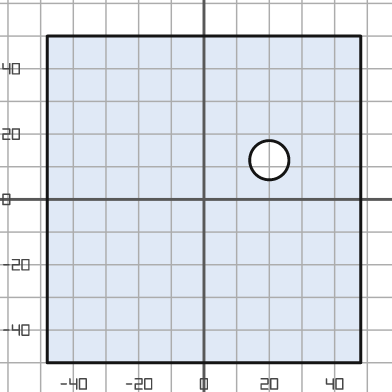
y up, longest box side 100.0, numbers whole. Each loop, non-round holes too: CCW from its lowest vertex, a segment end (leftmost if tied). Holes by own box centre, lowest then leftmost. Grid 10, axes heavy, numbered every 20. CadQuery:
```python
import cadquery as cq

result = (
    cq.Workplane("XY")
    .moveTo(-48.0, -50.0)
    .lineTo(48.0, -50.0)
    .lineTo(48.0, 50.0)
    .lineTo(-48.0, 50.0)
    .close()
    .moveTo(20.0, 12.0)
    .circle(6.0)
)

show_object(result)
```